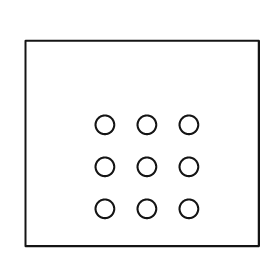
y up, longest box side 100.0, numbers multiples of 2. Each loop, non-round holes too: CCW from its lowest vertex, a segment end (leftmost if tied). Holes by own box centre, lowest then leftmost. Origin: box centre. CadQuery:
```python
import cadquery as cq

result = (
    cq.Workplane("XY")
    .moveTo(-50.0, -44.0)
    .lineTo(50.0, -44.0)
    .lineTo(50.0, 44.0)
    .lineTo(-50.0, 44.0)
    .close()
    .moveTo(-16.0, -28.0)
    .circle(4.0)
    .moveTo(2.0, -28.0)
    .circle(4.0)
    .moveTo(20.0, -28.0)
    .circle(4.0)
    .moveTo(-16.0, -10.0)
    .circle(4.0)
    .moveTo(2.0, -10.0)
    .circle(4.0)
    .moveTo(20.0, -10.0)
    .circle(4.0)
    .moveTo(-16.0, 8.0)
    .circle(4.0)
    .moveTo(2.0, 8.0)
    .circle(4.0)
    .moveTo(20.0, 8.0)
    .circle(4.0)
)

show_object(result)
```